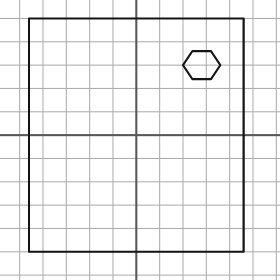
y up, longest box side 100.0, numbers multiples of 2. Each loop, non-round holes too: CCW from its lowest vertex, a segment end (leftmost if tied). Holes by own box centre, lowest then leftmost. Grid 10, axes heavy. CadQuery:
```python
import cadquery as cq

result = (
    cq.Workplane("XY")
    .moveTo(-46.0, -50.0)
    .lineTo(46.0, -50.0)
    .lineTo(46.0, 50.0)
    .lineTo(-46.0, 50.0)
    .close()
    .moveTo(24.0, 24.0)
    .lineTo(32.0, 24.0)
    .lineTo(36.0, 30.0)
    .lineTo(32.0, 36.0)
    .lineTo(24.0, 36.0)
    .lineTo(20.0, 30.0)
    .close()
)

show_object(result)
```